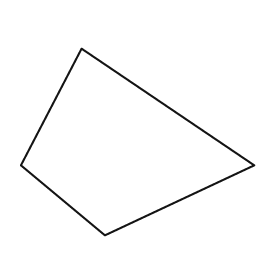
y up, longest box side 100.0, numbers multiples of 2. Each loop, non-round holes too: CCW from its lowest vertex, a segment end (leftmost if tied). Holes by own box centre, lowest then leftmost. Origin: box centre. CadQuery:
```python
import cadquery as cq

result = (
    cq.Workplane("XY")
    .moveTo(-14.0, -40.0)
    .lineTo(50.0, -10.0)
    .lineTo(-24.0, 40.0)
    .lineTo(-50.0, -10.0)
    .close()
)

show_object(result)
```